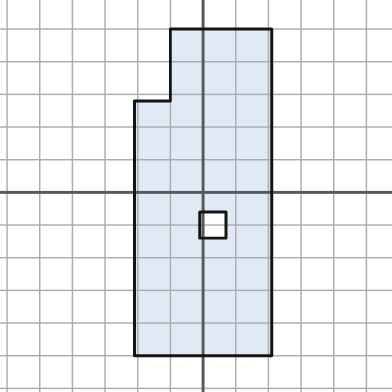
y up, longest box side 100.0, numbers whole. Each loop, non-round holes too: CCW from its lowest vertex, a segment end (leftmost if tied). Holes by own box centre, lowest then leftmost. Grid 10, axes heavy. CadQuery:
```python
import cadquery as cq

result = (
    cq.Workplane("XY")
    .moveTo(-21.0, -50.0)
    .lineTo(21.0, -50.0)
    .lineTo(21.0, 50.0)
    .lineTo(-10.0, 50.0)
    .lineTo(-10.0, 28.0)
    .lineTo(-21.0, 28.0)
    .close()
    .moveTo(-1.0, -14.0)
    .lineTo(7.0, -14.0)
    .lineTo(7.0, -6.0)
    .lineTo(-1.0, -6.0)
    .close()
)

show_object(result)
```